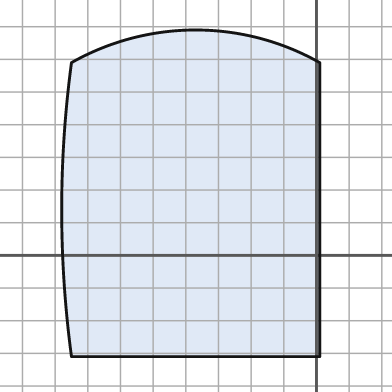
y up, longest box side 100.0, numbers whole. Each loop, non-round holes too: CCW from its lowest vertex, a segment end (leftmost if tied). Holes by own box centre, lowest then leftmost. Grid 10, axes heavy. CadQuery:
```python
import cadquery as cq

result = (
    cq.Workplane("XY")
    .moveTo(-75.0, -31.0)
    .lineTo(1.0, -31.0)
    .lineTo(1.0, 59.0)
    .threePointArc((-37.0, 69.0), (-75.0, 59.0))
    .threePointArc((-78.0, 14.0), (-75.0, -31.0))
    .close()
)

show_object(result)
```